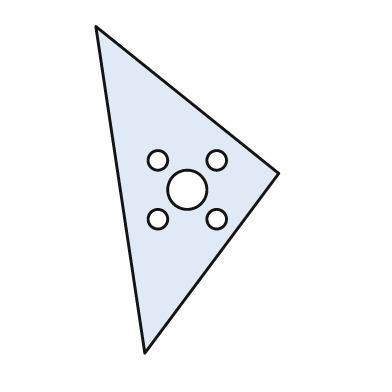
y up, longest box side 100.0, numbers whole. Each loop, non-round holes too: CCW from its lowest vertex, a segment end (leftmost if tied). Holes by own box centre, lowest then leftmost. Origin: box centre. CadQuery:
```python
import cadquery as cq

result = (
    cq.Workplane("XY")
    .moveTo(-13.0, -50.0)
    .lineTo(28.0, 5.0)
    .lineTo(-28.0, 50.0)
    .close()
    .moveTo(-9.0, -9.0)
    .circle(3.0)
    .moveTo(9.0, -9.0)
    .circle(3.0)
    .moveTo(0.0, 0.0)
    .circle(6.0)
    .moveTo(-9.0, 9.0)
    .circle(3.0)
    .moveTo(9.0, 9.0)
    .circle(3.0)
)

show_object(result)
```